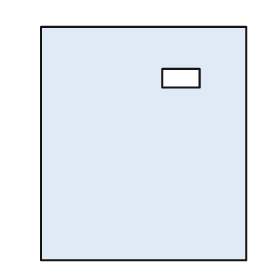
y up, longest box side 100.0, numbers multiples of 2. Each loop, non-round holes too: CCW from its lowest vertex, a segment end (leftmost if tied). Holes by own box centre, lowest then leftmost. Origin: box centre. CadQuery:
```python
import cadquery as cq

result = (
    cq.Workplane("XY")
    .moveTo(-44.0, -50.0)
    .lineTo(44.0, -50.0)
    .lineTo(44.0, 50.0)
    .lineTo(-44.0, 50.0)
    .close()
    .moveTo(8.0, 24.0)
    .lineTo(24.0, 24.0)
    .lineTo(24.0, 32.0)
    .lineTo(8.0, 32.0)
    .close()
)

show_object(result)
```